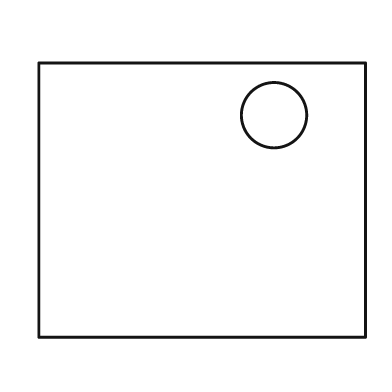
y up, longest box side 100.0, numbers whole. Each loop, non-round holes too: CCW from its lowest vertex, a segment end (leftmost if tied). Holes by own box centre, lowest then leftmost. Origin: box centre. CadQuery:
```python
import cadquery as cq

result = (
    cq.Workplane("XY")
    .moveTo(-50.0, -42.0)
    .lineTo(50.0, -42.0)
    .lineTo(50.0, 42.0)
    .lineTo(-50.0, 42.0)
    .close()
    .moveTo(22.0, 26.0)
    .circle(10.0)
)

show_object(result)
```